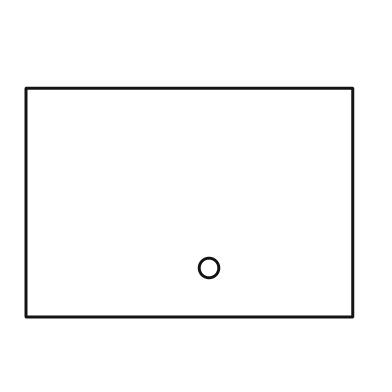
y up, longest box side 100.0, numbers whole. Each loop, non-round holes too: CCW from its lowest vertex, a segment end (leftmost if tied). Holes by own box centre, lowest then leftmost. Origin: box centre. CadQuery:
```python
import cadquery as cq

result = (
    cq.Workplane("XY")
    .moveTo(-50.0, -35.0)
    .lineTo(50.0, -35.0)
    .lineTo(50.0, 35.0)
    .lineTo(-50.0, 35.0)
    .close()
    .moveTo(6.0, -20.0)
    .circle(3.0)
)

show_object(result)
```